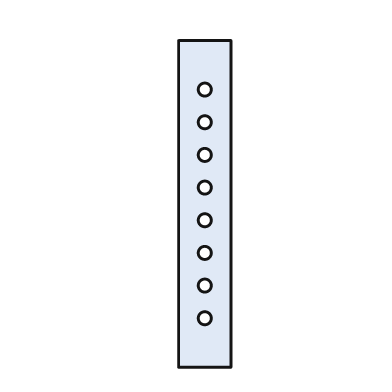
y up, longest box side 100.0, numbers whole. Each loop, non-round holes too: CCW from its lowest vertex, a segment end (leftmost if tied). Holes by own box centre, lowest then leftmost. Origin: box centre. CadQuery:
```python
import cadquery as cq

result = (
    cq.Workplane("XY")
    .moveTo(-8.0, -50.0)
    .lineTo(8.0, -50.0)
    .lineTo(8.0, 50.0)
    .lineTo(-8.0, 50.0)
    .close()
    .moveTo(0.0, -35.0)
    .circle(2.0)
    .moveTo(0.0, -25.0)
    .circle(2.0)
    .moveTo(0.0, -15.0)
    .circle(2.0)
    .moveTo(0.0, -5.0)
    .circle(2.0)
    .moveTo(0.0, 5.0)
    .circle(2.0)
    .moveTo(0.0, 15.0)
    .circle(2.0)
    .moveTo(0.0, 25.0)
    .circle(2.0)
    .moveTo(0.0, 35.0)
    .circle(2.0)
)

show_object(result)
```